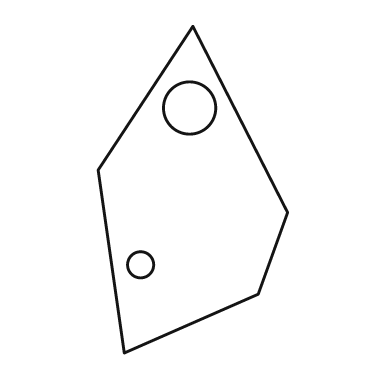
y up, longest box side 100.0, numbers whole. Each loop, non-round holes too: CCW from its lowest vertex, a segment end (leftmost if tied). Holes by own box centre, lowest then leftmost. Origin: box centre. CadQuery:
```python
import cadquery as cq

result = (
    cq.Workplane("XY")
    .moveTo(-21.0, -50.0)
    .lineTo(20.0, -32.0)
    .lineTo(29.0, -7.0)
    .lineTo(0.0, 50.0)
    .lineTo(-29.0, 6.0)
    .close()
    .moveTo(-16.0, -23.0)
    .circle(4.0)
    .moveTo(-1.0, 25.0)
    .circle(8.0)
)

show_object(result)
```